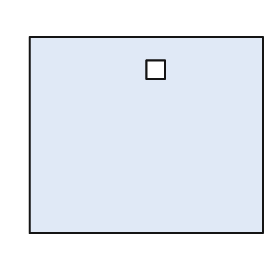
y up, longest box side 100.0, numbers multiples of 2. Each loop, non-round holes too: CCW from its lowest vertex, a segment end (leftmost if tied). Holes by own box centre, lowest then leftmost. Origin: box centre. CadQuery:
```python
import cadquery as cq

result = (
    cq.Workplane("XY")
    .moveTo(-50.0, -42.0)
    .lineTo(50.0, -42.0)
    .lineTo(50.0, 42.0)
    .lineTo(-50.0, 42.0)
    .close()
    .moveTo(0.0, 24.0)
    .lineTo(8.0, 24.0)
    .lineTo(8.0, 32.0)
    .lineTo(0.0, 32.0)
    .close()
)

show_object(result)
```